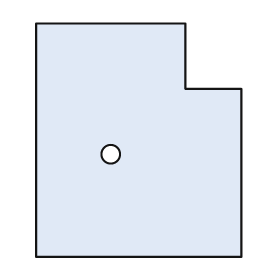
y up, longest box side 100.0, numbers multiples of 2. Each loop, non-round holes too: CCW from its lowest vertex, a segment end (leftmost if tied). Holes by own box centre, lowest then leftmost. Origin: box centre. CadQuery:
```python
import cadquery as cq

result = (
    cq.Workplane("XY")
    .moveTo(-44.0, -50.0)
    .lineTo(44.0, -50.0)
    .lineTo(44.0, 22.0)
    .lineTo(20.0, 22.0)
    .lineTo(20.0, 50.0)
    .lineTo(-44.0, 50.0)
    .close()
    .moveTo(-12.0, -6.0)
    .circle(4.0)
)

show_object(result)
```